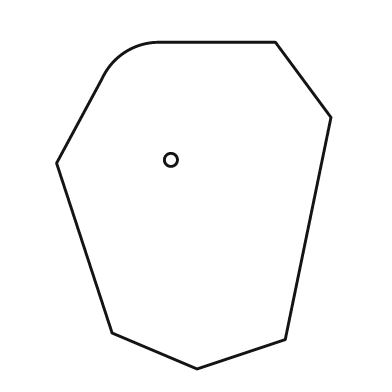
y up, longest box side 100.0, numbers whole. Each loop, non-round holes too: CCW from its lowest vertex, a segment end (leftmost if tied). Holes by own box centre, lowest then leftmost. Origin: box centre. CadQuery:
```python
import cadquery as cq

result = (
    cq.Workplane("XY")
    .moveTo(1.0, -50.0)
    .lineTo(28.0, -41.0)
    .lineTo(42.0, 27.0)
    .lineTo(25.0, 50.0)
    .lineTo(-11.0, 50.0)
    .threePointArc((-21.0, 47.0), (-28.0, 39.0))
    .lineTo(-42.0, 13.0)
    .lineTo(-25.0, -39.0)
    .close()
    .moveTo(-7.0, 14.0)
    .circle(2.0)
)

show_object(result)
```